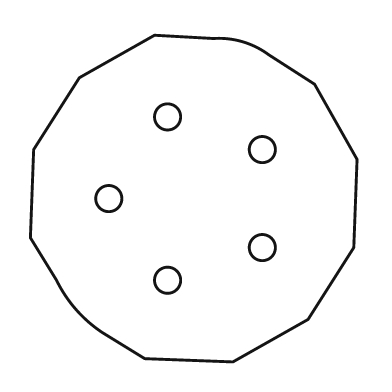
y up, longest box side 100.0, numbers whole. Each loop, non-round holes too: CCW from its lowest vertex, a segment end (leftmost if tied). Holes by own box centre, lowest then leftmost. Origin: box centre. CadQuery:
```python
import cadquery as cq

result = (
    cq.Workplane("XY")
    .moveTo(12.0, -50.0)
    .lineTo(35.0, -37.0)
    .lineTo(49.0, -15.0)
    .lineTo(50.0, 12.0)
    .lineTo(37.0, 35.0)
    .lineTo(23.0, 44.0)
    .threePointArc((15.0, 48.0), (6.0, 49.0))
    .lineTo(-12.0, 50.0)
    .lineTo(-35.0, 37.0)
    .lineTo(-49.0, 15.0)
    .lineTo(-50.0, -12.0)
    .lineTo(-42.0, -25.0)
    .threePointArc((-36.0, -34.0), (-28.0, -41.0))
    .lineTo(-15.0, -49.0)
    .close()
    .moveTo(-8.0, -25.0)
    .circle(4.0)
    .moveTo(21.0, -15.0)
    .circle(4.0)
    .moveTo(-26.0, 0.0)
    .circle(4.0)
    .moveTo(21.0, 15.0)
    .circle(4.0)
    .moveTo(-8.0, 25.0)
    .circle(4.0)
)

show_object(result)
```